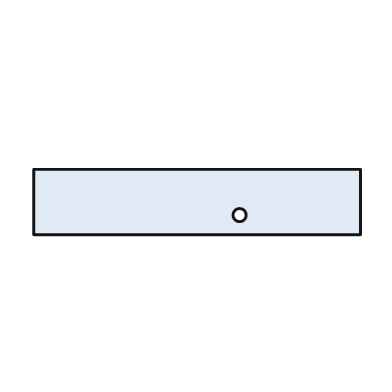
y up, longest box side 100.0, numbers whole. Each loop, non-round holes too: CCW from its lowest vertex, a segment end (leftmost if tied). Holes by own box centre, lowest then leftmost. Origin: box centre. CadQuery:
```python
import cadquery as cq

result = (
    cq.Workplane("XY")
    .moveTo(-50.0, -10.0)
    .lineTo(50.0, -10.0)
    .lineTo(50.0, 10.0)
    .lineTo(-50.0, 10.0)
    .close()
    .moveTo(13.0, -4.0)
    .circle(2.0)
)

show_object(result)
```